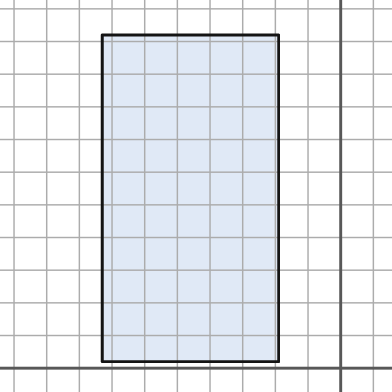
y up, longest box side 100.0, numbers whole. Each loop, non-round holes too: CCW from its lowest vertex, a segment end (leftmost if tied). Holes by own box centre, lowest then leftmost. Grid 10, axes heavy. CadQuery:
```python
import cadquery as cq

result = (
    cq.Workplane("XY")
    .moveTo(-73.0, 2.0)
    .lineTo(-19.0, 2.0)
    .lineTo(-19.0, 102.0)
    .lineTo(-73.0, 102.0)
    .close()
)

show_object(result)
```